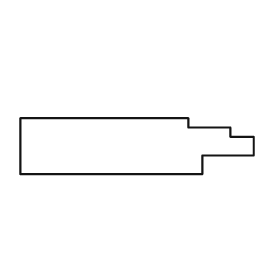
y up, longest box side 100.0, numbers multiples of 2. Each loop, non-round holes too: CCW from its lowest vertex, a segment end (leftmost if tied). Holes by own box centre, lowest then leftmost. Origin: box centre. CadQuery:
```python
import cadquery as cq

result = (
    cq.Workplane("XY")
    .moveTo(-50.0, -12.0)
    .lineTo(28.0, -12.0)
    .lineTo(28.0, -4.0)
    .lineTo(50.0, -4.0)
    .lineTo(50.0, 4.0)
    .lineTo(40.0, 4.0)
    .lineTo(40.0, 8.0)
    .lineTo(22.0, 8.0)
    .lineTo(22.0, 12.0)
    .lineTo(-50.0, 12.0)
    .close()
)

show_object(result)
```